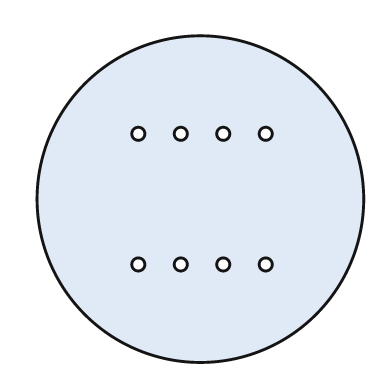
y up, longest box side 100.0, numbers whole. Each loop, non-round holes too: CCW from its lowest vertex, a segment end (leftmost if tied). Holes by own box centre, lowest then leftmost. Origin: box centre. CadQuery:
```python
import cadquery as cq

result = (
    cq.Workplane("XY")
    .moveTo(0.0, 0.0)
    .circle(50.0)
    .moveTo(-19.0, -20.0)
    .circle(2.0)
    .moveTo(-6.0, -20.0)
    .circle(2.0)
    .moveTo(7.0, -20.0)
    .circle(2.0)
    .moveTo(20.0, -20.0)
    .circle(2.0)
    .moveTo(-19.0, 20.0)
    .circle(2.0)
    .moveTo(-6.0, 20.0)
    .circle(2.0)
    .moveTo(7.0, 20.0)
    .circle(2.0)
    .moveTo(20.0, 20.0)
    .circle(2.0)
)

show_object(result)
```